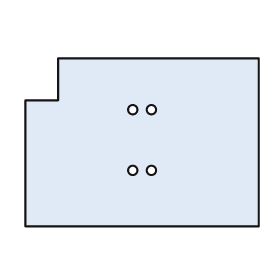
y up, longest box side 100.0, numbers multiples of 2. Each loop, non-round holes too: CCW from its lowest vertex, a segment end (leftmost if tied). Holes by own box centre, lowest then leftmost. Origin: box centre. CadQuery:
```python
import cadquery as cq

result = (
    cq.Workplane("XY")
    .moveTo(-50.0, -36.0)
    .lineTo(50.0, -36.0)
    .lineTo(50.0, 36.0)
    .lineTo(-36.0, 36.0)
    .lineTo(-36.0, 18.0)
    .lineTo(-50.0, 18.0)
    .close()
    .moveTo(-4.0, -12.0)
    .circle(2.0)
    .moveTo(4.0, -12.0)
    .circle(2.0)
    .moveTo(-4.0, 14.0)
    .circle(2.0)
    .moveTo(4.0, 14.0)
    .circle(2.0)
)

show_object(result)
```